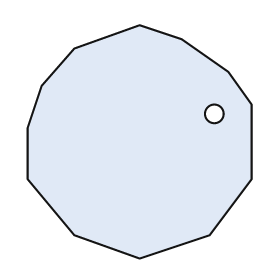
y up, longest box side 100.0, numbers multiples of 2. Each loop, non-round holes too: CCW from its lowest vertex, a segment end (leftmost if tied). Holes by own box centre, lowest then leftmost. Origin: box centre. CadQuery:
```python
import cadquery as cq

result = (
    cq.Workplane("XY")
    .moveTo(0.0, -50.0)
    .lineTo(30.0, -40.0)
    .lineTo(48.0, -16.0)
    .lineTo(48.0, 16.0)
    .lineTo(38.0, 30.0)
    .lineTo(18.0, 44.0)
    .lineTo(0.0, 50.0)
    .lineTo(-28.0, 40.0)
    .lineTo(-42.0, 24.0)
    .lineTo(-48.0, 6.0)
    .lineTo(-48.0, -16.0)
    .lineTo(-28.0, -40.0)
    .close()
    .moveTo(32.0, 12.0)
    .circle(4.0)
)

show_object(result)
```